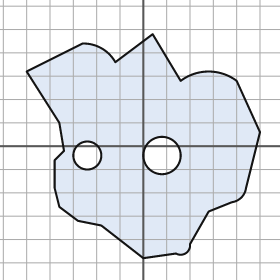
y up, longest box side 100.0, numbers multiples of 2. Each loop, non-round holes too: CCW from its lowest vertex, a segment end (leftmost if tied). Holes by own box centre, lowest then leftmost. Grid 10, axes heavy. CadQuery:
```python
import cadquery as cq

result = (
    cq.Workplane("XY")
    .moveTo(0.0, -48.0)
    .lineTo(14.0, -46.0)
    .threePointArc((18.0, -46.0), (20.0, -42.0))
    .lineTo(28.0, -28.0)
    .lineTo(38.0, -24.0)
    .threePointArc((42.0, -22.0), (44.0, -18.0))
    .lineTo(50.0, 6.0)
    .lineTo(40.0, 28.0)
    .threePointArc((28.0, 32.0), (16.0, 28.0))
    .lineTo(4.0, 48.0)
    .lineTo(-12.0, 36.0)
    .threePointArc((-18.0, 42.0), (-26.0, 44.0))
    .lineTo(-50.0, 32.0)
    .lineTo(-36.0, 10.0)
    .lineTo(-34.0, -2.0)
    .lineTo(-38.0, -6.0)
    .lineTo(-38.0, -18.0)
    .lineTo(-36.0, -26.0)
    .lineTo(-28.0, -32.0)
    .lineTo(-18.0, -34.0)
    .close()
    .moveTo(-24.0, -4.0)
    .circle(6.0)
    .moveTo(8.0, -4.0)
    .circle(8.0)
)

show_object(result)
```